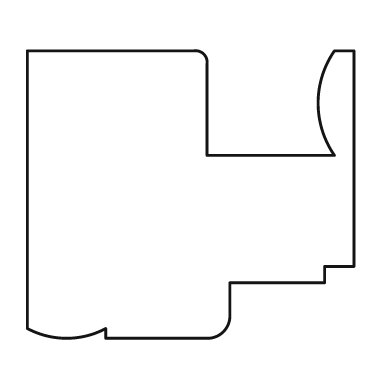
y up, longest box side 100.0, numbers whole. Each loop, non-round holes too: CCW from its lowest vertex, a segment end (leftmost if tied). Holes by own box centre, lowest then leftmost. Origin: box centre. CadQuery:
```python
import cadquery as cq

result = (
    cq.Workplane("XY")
    .moveTo(-26.0, -44.0)
    .lineTo(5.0, -44.0)
    .threePointArc((10.0, -42.0), (12.0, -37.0))
    .lineTo(12.0, -27.0)
    .lineTo(41.0, -27.0)
    .lineTo(41.0, -22.0)
    .lineTo(50.0, -22.0)
    .lineTo(50.0, 44.0)
    .lineTo(44.0, 44.0)
    .threePointArc((39.0, 28.0), (44.0, 12.0))
    .lineTo(5.0, 12.0)
    .lineTo(5.0, 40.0)
    .threePointArc((4.0, 43.0), (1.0, 44.0))
    .lineTo(-50.0, 44.0)
    .lineTo(-50.0, -41.0)
    .threePointArc((-38.0, -44.0), (-26.0, -41.0))
    .close()
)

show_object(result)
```